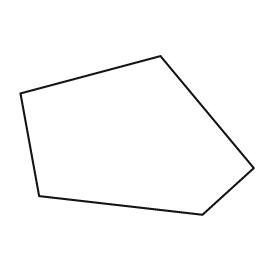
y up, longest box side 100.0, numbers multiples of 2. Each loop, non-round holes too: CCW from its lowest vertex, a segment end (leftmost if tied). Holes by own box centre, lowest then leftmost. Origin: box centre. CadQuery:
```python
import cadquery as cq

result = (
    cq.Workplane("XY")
    .moveTo(28.0, -34.0)
    .lineTo(50.0, -14.0)
    .lineTo(10.0, 34.0)
    .lineTo(-50.0, 18.0)
    .lineTo(-42.0, -26.0)
    .close()
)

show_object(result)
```